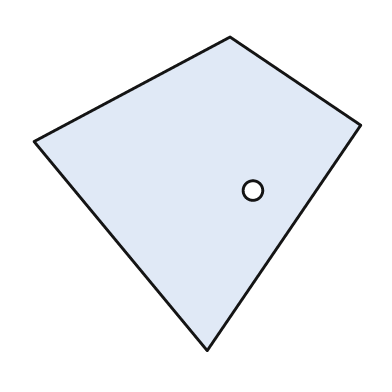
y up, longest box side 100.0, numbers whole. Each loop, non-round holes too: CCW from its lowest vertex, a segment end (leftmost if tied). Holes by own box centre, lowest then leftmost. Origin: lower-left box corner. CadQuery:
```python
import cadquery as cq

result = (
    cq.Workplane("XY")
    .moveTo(53.0, 0.0)
    .lineTo(100.0, 69.0)
    .lineTo(60.0, 96.0)
    .lineTo(0.0, 64.0)
    .close()
    .moveTo(67.0, 49.0)
    .circle(3.0)
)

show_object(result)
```